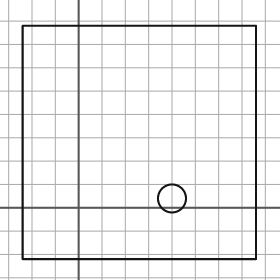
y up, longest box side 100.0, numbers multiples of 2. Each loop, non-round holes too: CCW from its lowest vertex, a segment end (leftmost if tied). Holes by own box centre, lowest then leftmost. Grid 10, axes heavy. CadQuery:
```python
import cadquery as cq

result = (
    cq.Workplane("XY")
    .moveTo(-24.0, -22.0)
    .lineTo(76.0, -22.0)
    .lineTo(76.0, 78.0)
    .lineTo(-24.0, 78.0)
    .close()
    .moveTo(40.0, 4.0)
    .circle(6.0)
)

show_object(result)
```